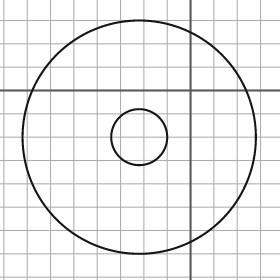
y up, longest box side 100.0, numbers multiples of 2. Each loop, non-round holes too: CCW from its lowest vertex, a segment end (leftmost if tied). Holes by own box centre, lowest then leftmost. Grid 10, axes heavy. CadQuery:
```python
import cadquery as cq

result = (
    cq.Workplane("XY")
    .moveTo(-22.0, -20.0)
    .circle(50.0)
    .moveTo(-22.0, -20.0)
    .circle(12.0)
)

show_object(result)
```